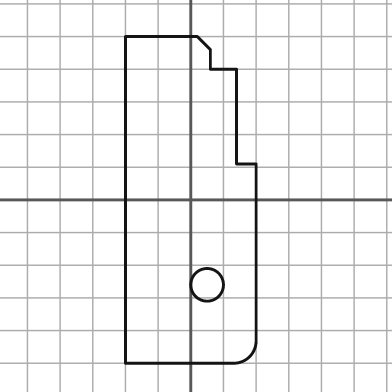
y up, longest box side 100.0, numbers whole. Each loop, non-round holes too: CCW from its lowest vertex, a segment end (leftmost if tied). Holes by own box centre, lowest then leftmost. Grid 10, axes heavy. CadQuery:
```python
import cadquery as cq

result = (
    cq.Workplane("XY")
    .moveTo(-20.0, -50.0)
    .lineTo(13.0, -50.0)
    .threePointArc((18.0, -48.0), (20.0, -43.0))
    .lineTo(20.0, 11.0)
    .lineTo(14.0, 11.0)
    .lineTo(14.0, 40.0)
    .lineTo(6.0, 40.0)
    .lineTo(6.0, 46.0)
    .lineTo(2.0, 50.0)
    .lineTo(-20.0, 50.0)
    .close()
    .moveTo(5.0, -26.0)
    .circle(5.0)
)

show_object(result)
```